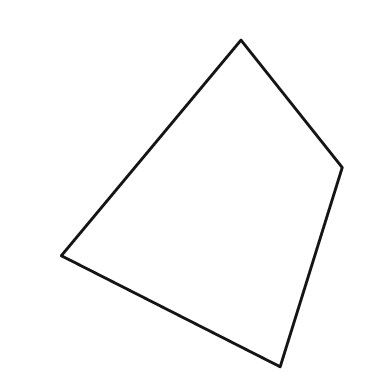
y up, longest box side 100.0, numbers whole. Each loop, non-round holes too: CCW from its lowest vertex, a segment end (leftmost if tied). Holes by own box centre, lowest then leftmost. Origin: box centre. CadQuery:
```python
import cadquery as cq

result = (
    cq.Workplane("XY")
    .moveTo(24.0, -50.0)
    .lineTo(43.0, 11.0)
    .lineTo(12.0, 50.0)
    .lineTo(-43.0, -16.0)
    .close()
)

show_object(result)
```